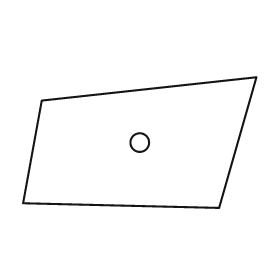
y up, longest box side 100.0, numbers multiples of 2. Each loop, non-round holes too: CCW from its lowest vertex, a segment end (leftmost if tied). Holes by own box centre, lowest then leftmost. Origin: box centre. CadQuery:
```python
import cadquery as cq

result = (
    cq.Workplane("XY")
    .moveTo(34.0, -28.0)
    .lineTo(50.0, 28.0)
    .lineTo(-42.0, 18.0)
    .lineTo(-50.0, -26.0)
    .close()
    .moveTo(0.0, 0.0)
    .circle(4.0)
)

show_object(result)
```